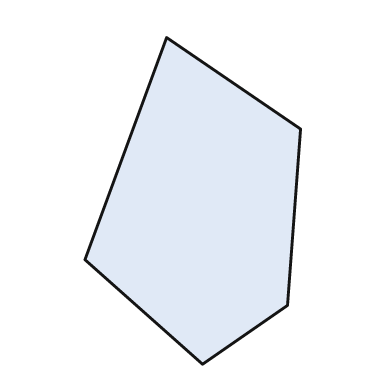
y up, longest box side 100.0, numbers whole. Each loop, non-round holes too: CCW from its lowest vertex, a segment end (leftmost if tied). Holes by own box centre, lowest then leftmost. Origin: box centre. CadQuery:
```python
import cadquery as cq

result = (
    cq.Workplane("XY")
    .moveTo(3.0, -50.0)
    .lineTo(29.0, -32.0)
    .lineTo(33.0, 22.0)
    .lineTo(-8.0, 50.0)
    .lineTo(-33.0, -18.0)
    .close()
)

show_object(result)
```